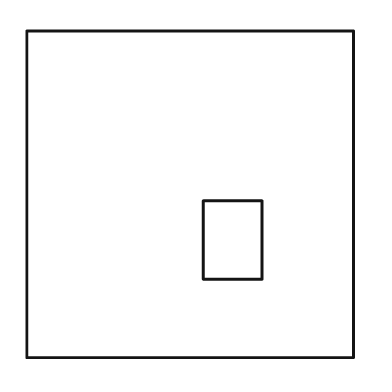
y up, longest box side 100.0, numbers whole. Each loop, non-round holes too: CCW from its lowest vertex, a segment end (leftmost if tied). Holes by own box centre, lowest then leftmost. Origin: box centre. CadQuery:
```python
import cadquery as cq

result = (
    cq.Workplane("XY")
    .moveTo(-50.0, -50.0)
    .lineTo(50.0, -50.0)
    .lineTo(50.0, 50.0)
    .lineTo(-50.0, 50.0)
    .close()
    .moveTo(4.0, -26.0)
    .lineTo(22.0, -26.0)
    .lineTo(22.0, -2.0)
    .lineTo(4.0, -2.0)
    .close()
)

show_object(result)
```